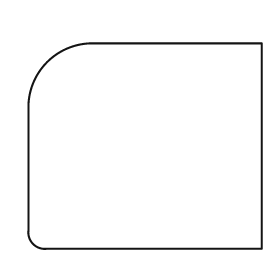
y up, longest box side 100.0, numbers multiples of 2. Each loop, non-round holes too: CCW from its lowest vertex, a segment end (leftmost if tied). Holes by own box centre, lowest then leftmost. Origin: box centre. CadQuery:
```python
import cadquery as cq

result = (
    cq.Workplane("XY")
    .moveTo(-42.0, -44.0)
    .lineTo(50.0, -44.0)
    .lineTo(50.0, 44.0)
    .lineTo(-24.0, 44.0)
    .threePointArc((-42.0, 36.0), (-50.0, 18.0))
    .lineTo(-50.0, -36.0)
    .threePointArc((-48.0, -42.0), (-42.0, -44.0))
    .close()
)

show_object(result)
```